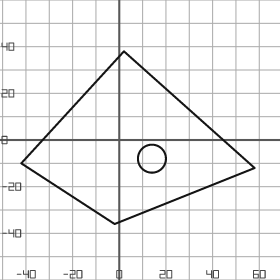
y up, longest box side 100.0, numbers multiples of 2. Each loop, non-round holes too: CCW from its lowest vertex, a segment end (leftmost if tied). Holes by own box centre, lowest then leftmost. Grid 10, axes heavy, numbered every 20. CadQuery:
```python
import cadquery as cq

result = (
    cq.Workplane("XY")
    .moveTo(-2.0, -36.0)
    .lineTo(58.0, -12.0)
    .lineTo(2.0, 38.0)
    .lineTo(-42.0, -10.0)
    .close()
    .moveTo(14.0, -8.0)
    .circle(6.0)
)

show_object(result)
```